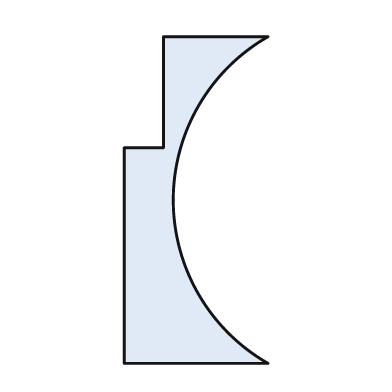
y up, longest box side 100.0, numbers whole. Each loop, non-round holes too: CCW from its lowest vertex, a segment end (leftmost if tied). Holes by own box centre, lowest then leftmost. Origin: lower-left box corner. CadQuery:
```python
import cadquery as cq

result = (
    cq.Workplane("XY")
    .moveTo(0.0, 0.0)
    .lineTo(44.0, 0.0)
    .threePointArc((15.0, 50.0), (44.0, 100.0))
    .lineTo(12.0, 100.0)
    .lineTo(12.0, 66.0)
    .lineTo(0.0, 66.0)
    .close()
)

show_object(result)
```